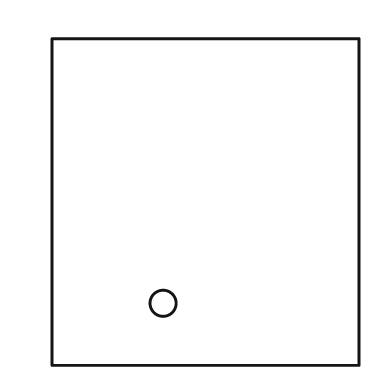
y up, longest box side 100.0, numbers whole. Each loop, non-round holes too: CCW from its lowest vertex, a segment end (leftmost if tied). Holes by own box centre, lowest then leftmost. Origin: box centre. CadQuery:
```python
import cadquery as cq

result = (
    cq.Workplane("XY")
    .moveTo(-47.0, -50.0)
    .lineTo(47.0, -50.0)
    .lineTo(47.0, 50.0)
    .lineTo(-47.0, 50.0)
    .close()
    .moveTo(-13.0, -31.0)
    .circle(4.0)
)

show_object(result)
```